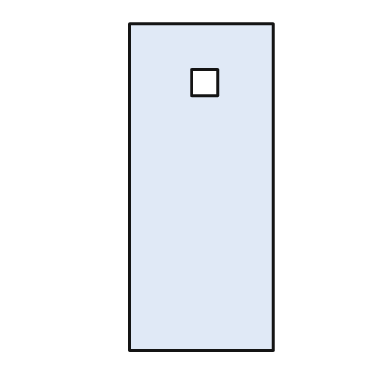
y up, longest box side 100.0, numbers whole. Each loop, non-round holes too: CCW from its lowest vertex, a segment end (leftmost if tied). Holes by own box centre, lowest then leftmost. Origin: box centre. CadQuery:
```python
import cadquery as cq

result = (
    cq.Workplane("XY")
    .moveTo(-22.0, -50.0)
    .lineTo(22.0, -50.0)
    .lineTo(22.0, 50.0)
    .lineTo(-22.0, 50.0)
    .close()
    .moveTo(-3.0, 28.0)
    .lineTo(5.0, 28.0)
    .lineTo(5.0, 36.0)
    .lineTo(-3.0, 36.0)
    .close()
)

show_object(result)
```